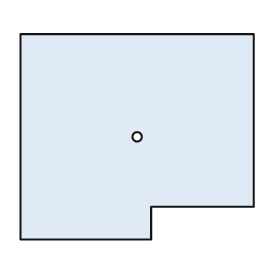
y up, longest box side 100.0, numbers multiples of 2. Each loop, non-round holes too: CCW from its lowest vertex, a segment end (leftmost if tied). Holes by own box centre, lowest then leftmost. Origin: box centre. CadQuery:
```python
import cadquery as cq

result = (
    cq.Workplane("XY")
    .moveTo(-50.0, -44.0)
    .lineTo(6.0, -44.0)
    .lineTo(6.0, -30.0)
    .lineTo(50.0, -30.0)
    .lineTo(50.0, 44.0)
    .lineTo(-50.0, 44.0)
    .close()
    .moveTo(0.0, 0.0)
    .circle(2.0)
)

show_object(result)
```